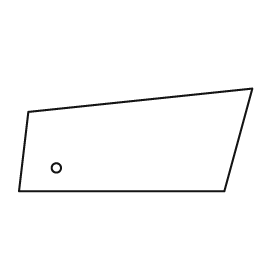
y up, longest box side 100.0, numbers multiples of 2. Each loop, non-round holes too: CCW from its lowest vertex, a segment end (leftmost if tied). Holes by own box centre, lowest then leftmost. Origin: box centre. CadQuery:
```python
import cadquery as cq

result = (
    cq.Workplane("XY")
    .moveTo(-50.0, -22.0)
    .lineTo(38.0, -22.0)
    .lineTo(50.0, 22.0)
    .lineTo(-46.0, 12.0)
    .close()
    .moveTo(-34.0, -12.0)
    .circle(2.0)
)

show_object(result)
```